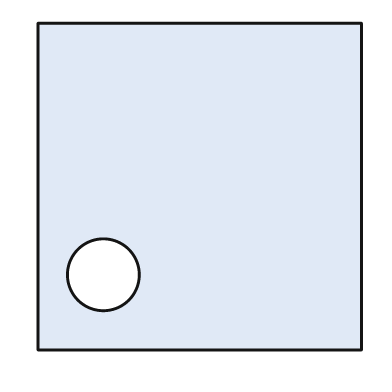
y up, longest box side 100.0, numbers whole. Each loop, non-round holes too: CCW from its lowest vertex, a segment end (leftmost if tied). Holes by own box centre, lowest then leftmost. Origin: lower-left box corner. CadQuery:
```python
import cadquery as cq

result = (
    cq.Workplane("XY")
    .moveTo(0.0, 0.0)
    .lineTo(99.0, 0.0)
    .lineTo(99.0, 100.0)
    .lineTo(0.0, 100.0)
    .close()
    .moveTo(20.0, 23.0)
    .circle(11.0)
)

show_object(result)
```